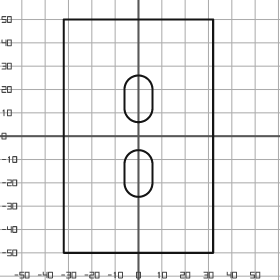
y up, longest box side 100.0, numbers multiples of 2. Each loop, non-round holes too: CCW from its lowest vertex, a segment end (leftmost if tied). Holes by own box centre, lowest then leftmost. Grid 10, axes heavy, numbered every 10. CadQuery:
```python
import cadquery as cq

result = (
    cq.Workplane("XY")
    .moveTo(-32.0, -50.0)
    .lineTo(32.0, -50.0)
    .lineTo(32.0, 50.0)
    .lineTo(-32.0, 50.0)
    .close()
    .moveTo(-6.0, -20.0)
    .threePointArc((0.0, -26.0), (6.0, -20.0))
    .lineTo(6.0, -12.0)
    .threePointArc((0.0, -6.0), (-6.0, -12.0))
    .close()
    .moveTo(-6.0, 12.0)
    .threePointArc((0.0, 6.0), (6.0, 12.0))
    .lineTo(6.0, 20.0)
    .threePointArc((0.0, 26.0), (-6.0, 20.0))
    .close()
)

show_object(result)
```